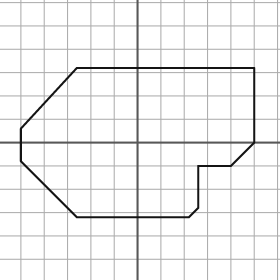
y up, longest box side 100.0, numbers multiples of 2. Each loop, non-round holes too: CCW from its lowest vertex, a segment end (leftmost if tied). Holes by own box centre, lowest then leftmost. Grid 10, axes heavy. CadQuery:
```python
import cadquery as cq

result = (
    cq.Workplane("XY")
    .moveTo(-26.0, -32.0)
    .lineTo(22.0, -32.0)
    .lineTo(26.0, -28.0)
    .lineTo(26.0, -10.0)
    .lineTo(40.0, -10.0)
    .lineTo(50.0, 0.0)
    .lineTo(50.0, 32.0)
    .lineTo(-26.0, 32.0)
    .lineTo(-50.0, 6.0)
    .lineTo(-50.0, -8.0)
    .close()
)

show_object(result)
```